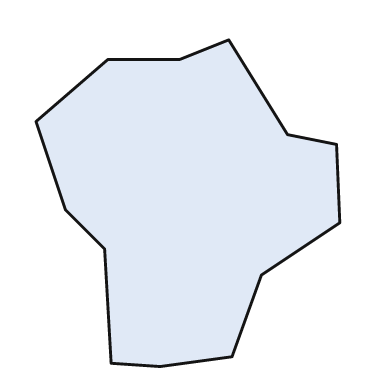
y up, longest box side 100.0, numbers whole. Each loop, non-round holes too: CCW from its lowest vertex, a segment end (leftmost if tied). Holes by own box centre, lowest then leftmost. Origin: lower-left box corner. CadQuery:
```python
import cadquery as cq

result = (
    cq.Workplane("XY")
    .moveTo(38.0, 0.0)
    .lineTo(60.0, 3.0)
    .lineTo(69.0, 28.0)
    .lineTo(93.0, 44.0)
    .lineTo(92.0, 68.0)
    .lineTo(77.0, 71.0)
    .lineTo(59.0, 100.0)
    .lineTo(44.0, 94.0)
    .lineTo(22.0, 94.0)
    .lineTo(0.0, 75.0)
    .lineTo(9.0, 48.0)
    .lineTo(21.0, 36.0)
    .lineTo(23.0, 1.0)
    .close()
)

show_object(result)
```